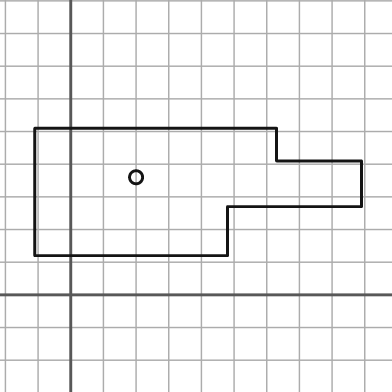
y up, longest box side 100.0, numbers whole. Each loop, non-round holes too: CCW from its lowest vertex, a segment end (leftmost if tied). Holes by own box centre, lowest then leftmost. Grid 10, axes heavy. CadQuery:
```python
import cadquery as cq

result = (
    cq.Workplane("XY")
    .moveTo(-11.0, 12.0)
    .lineTo(48.0, 12.0)
    .lineTo(48.0, 27.0)
    .lineTo(89.0, 27.0)
    .lineTo(89.0, 41.0)
    .lineTo(63.0, 41.0)
    .lineTo(63.0, 51.0)
    .lineTo(-11.0, 51.0)
    .close()
    .moveTo(20.0, 36.0)
    .circle(2.0)
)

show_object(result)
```